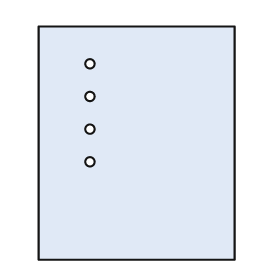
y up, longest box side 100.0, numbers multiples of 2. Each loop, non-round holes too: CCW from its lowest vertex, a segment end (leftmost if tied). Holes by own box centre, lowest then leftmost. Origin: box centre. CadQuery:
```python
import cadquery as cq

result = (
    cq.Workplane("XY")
    .moveTo(-42.0, -50.0)
    .lineTo(42.0, -50.0)
    .lineTo(42.0, 50.0)
    .lineTo(-42.0, 50.0)
    .close()
    .moveTo(-20.0, -8.0)
    .circle(2.0)
    .moveTo(-20.0, 6.0)
    .circle(2.0)
    .moveTo(-20.0, 20.0)
    .circle(2.0)
    .moveTo(-20.0, 34.0)
    .circle(2.0)
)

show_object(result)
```